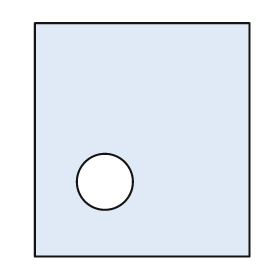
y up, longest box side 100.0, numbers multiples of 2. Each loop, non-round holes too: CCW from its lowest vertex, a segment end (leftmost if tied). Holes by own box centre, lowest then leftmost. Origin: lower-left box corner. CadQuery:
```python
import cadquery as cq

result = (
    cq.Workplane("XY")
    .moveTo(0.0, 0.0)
    .lineTo(92.0, 0.0)
    .lineTo(92.0, 100.0)
    .lineTo(0.0, 100.0)
    .close()
    .moveTo(30.0, 32.0)
    .circle(12.0)
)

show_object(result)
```